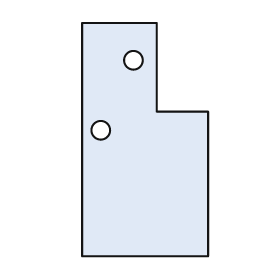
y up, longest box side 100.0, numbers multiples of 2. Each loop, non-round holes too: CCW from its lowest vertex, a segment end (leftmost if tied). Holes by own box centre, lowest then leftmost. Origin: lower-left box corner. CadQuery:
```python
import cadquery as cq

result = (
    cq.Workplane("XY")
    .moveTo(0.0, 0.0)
    .lineTo(54.0, 0.0)
    .lineTo(54.0, 62.0)
    .lineTo(32.0, 62.0)
    .lineTo(32.0, 100.0)
    .lineTo(0.0, 100.0)
    .close()
    .moveTo(8.0, 54.0)
    .circle(4.0)
    .moveTo(22.0, 84.0)
    .circle(4.0)
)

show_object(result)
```